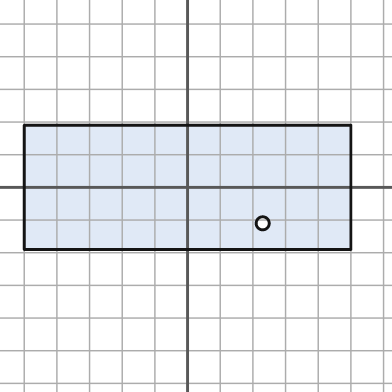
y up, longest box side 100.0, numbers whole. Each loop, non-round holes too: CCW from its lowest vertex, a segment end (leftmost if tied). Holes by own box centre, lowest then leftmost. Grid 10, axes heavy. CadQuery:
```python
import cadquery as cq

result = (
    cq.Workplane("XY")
    .moveTo(-50.0, -19.0)
    .lineTo(50.0, -19.0)
    .lineTo(50.0, 19.0)
    .lineTo(-50.0, 19.0)
    .close()
    .moveTo(23.0, -11.0)
    .circle(2.0)
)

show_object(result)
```